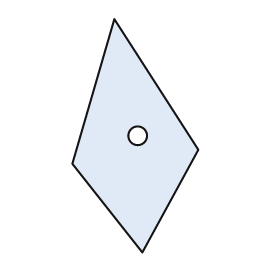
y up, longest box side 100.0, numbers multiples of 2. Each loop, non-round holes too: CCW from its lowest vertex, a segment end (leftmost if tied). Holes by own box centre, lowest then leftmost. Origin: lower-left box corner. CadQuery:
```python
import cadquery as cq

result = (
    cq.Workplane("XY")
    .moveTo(30.0, 0.0)
    .lineTo(54.0, 44.0)
    .lineTo(18.0, 100.0)
    .lineTo(0.0, 38.0)
    .close()
    .moveTo(28.0, 50.0)
    .circle(4.0)
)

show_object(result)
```